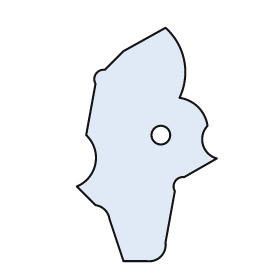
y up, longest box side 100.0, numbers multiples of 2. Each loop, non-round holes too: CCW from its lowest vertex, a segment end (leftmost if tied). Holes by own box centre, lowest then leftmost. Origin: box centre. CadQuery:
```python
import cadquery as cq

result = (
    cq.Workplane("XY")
    .moveTo(-10.0, -50.0)
    .lineTo(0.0, -50.0)
    .threePointArc((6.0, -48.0), (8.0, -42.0))
    .lineTo(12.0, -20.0)
    .threePointArc((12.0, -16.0), (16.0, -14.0))
    .lineTo(30.0, -6.0)
    .threePointArc((24.0, 0.0), (26.0, 8.0))
    .threePointArc((22.0, 16.0), (14.0, 20.0))
    .threePointArc((16.0, 36.0), (8.0, 50.0))
    .lineTo(-10.0, 40.0)
    .lineTo(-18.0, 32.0)
    .threePointArc((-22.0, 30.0), (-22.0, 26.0))
    .lineTo(-26.0, 4.0)
    .threePointArc((-22.0, -8.0), (-30.0, -18.0))
    .lineTo(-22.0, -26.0)
    .threePointArc((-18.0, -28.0), (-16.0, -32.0))
    .close()
    .moveTo(6.0, 4.0)
    .circle(4.0)
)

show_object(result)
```